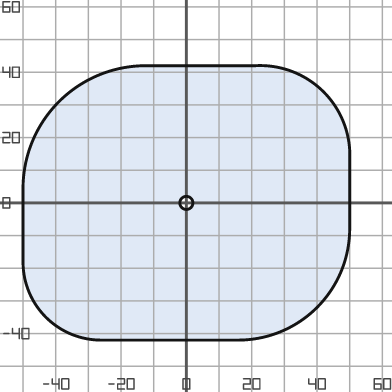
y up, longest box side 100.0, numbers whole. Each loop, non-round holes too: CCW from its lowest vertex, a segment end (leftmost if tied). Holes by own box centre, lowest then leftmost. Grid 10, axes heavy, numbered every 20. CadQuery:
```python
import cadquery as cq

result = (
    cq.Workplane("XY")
    .moveTo(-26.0, -42.0)
    .lineTo(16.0, -42.0)
    .threePointArc((40.0, -32.0), (50.0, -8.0))
    .lineTo(50.0, 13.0)
    .threePointArc((42.0, 34.0), (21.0, 42.0))
    .lineTo(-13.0, 42.0)
    .threePointArc((-39.0, 31.0), (-50.0, 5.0))
    .lineTo(-50.0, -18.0)
    .threePointArc((-43.0, -35.0), (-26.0, -42.0))
    .close()
    .moveTo(0.0, 0.0)
    .circle(2.0)
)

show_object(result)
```